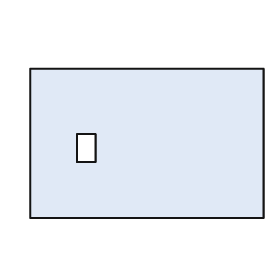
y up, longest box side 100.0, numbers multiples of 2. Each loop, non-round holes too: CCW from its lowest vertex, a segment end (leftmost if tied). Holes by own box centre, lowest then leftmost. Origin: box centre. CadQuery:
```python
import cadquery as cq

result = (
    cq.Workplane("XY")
    .moveTo(-50.0, -32.0)
    .lineTo(50.0, -32.0)
    .lineTo(50.0, 32.0)
    .lineTo(-50.0, 32.0)
    .close()
    .moveTo(-30.0, -8.0)
    .lineTo(-22.0, -8.0)
    .lineTo(-22.0, 4.0)
    .lineTo(-30.0, 4.0)
    .close()
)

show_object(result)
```